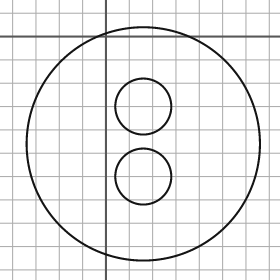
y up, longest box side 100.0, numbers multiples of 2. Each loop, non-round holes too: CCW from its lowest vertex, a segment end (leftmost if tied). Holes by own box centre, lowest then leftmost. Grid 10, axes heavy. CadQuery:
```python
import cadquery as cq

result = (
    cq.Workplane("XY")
    .moveTo(16.0, -46.0)
    .circle(50.0)
    .moveTo(16.0, -60.0)
    .circle(12.0)
    .moveTo(16.0, -30.0)
    .circle(12.0)
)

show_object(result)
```